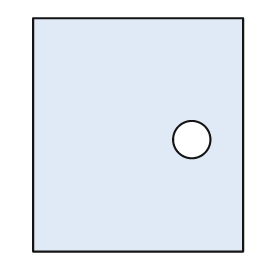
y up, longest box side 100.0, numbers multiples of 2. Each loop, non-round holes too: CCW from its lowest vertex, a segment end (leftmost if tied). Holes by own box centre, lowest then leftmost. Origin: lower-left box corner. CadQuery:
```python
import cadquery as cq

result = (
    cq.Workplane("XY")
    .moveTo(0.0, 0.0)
    .lineTo(90.0, 0.0)
    .lineTo(90.0, 100.0)
    .lineTo(0.0, 100.0)
    .close()
    .moveTo(68.0, 48.0)
    .circle(8.0)
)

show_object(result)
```